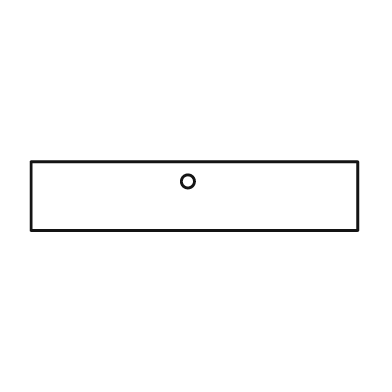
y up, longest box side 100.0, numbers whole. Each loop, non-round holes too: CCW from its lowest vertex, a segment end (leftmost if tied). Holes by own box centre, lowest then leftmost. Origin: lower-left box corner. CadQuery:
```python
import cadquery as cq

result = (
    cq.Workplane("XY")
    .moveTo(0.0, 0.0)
    .lineTo(100.0, 0.0)
    .lineTo(100.0, 21.0)
    .lineTo(0.0, 21.0)
    .close()
    .moveTo(48.0, 15.0)
    .circle(2.0)
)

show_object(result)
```